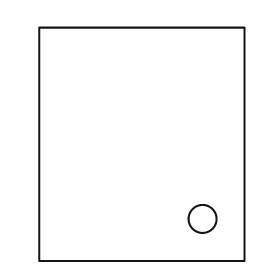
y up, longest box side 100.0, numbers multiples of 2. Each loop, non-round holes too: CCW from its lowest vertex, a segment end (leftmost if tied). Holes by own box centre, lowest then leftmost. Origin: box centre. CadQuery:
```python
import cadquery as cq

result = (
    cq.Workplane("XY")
    .moveTo(-44.0, -50.0)
    .lineTo(44.0, -50.0)
    .lineTo(44.0, 50.0)
    .lineTo(-44.0, 50.0)
    .close()
    .moveTo(26.0, -32.0)
    .circle(6.0)
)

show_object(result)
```